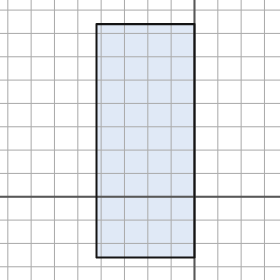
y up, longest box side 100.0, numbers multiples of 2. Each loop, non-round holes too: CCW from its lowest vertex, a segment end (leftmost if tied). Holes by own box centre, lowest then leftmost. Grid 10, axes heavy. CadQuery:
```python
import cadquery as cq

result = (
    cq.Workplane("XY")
    .moveTo(-42.0, -26.0)
    .lineTo(0.0, -26.0)
    .lineTo(0.0, 74.0)
    .lineTo(-42.0, 74.0)
    .close()
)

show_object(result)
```